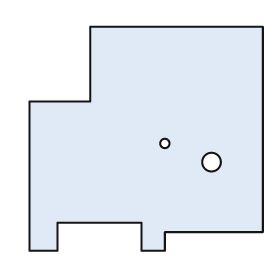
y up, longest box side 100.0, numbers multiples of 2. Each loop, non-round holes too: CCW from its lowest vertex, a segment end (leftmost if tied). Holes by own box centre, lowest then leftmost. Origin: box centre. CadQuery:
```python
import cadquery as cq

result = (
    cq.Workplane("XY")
    .moveTo(-50.0, -48.0)
    .lineTo(-38.0, -48.0)
    .lineTo(-38.0, -36.0)
    .lineTo(-2.0, -36.0)
    .lineTo(-2.0, -48.0)
    .lineTo(8.0, -48.0)
    .lineTo(8.0, -40.0)
    .lineTo(50.0, -40.0)
    .lineTo(50.0, 48.0)
    .lineTo(-24.0, 48.0)
    .lineTo(-24.0, 16.0)
    .lineTo(-50.0, 16.0)
    .close()
    .moveTo(28.0, -10.0)
    .circle(4.0)
    .moveTo(8.0, -2.0)
    .circle(2.0)
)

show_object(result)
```